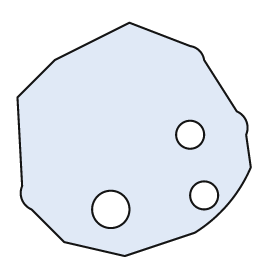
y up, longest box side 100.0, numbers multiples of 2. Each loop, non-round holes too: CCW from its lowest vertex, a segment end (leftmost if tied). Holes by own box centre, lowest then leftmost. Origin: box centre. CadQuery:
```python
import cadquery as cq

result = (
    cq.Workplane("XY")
    .moveTo(-4.0, -50.0)
    .lineTo(26.0, -40.0)
    .threePointArc((40.0, -28.0), (50.0, -12.0))
    .lineTo(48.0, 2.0)
    .threePointArc((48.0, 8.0), (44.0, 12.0))
    .lineTo(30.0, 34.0)
    .threePointArc((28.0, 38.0), (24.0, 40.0))
    .lineTo(-2.0, 50.0)
    .lineTo(-34.0, 34.0)
    .lineTo(-50.0, 18.0)
    .lineTo(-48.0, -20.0)
    .threePointArc((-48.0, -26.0), (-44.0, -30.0))
    .lineTo(-30.0, -44.0)
    .close()
    .moveTo(-10.0, -30.0)
    .circle(8.0)
    .moveTo(30.0, -24.0)
    .circle(6.0)
    .moveTo(24.0, 2.0)
    .circle(6.0)
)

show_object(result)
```